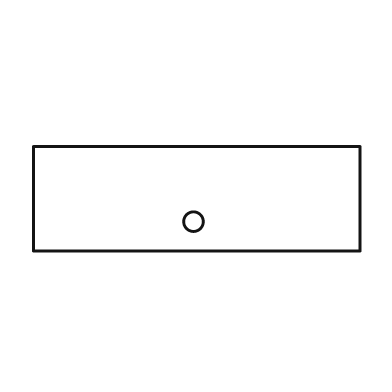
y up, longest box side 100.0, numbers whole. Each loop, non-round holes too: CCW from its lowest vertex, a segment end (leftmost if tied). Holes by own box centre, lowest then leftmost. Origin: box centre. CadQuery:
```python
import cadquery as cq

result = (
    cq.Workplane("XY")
    .moveTo(-50.0, -16.0)
    .lineTo(50.0, -16.0)
    .lineTo(50.0, 16.0)
    .lineTo(-50.0, 16.0)
    .close()
    .moveTo(-1.0, -7.0)
    .circle(3.0)
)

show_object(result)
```